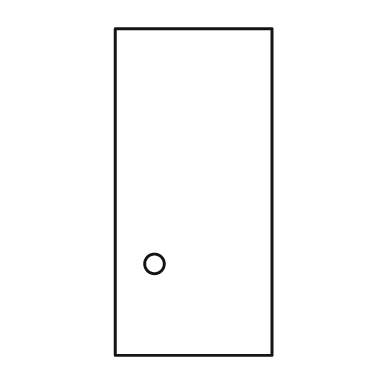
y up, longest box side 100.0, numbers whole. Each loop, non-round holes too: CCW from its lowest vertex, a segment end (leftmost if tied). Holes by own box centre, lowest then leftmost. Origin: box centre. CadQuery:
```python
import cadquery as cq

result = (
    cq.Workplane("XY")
    .moveTo(-24.0, -50.0)
    .lineTo(24.0, -50.0)
    .lineTo(24.0, 50.0)
    .lineTo(-24.0, 50.0)
    .close()
    .moveTo(-12.0, -22.0)
    .circle(3.0)
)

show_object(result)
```